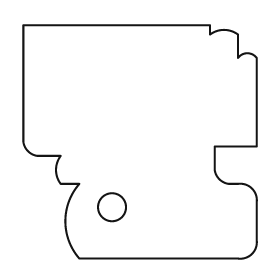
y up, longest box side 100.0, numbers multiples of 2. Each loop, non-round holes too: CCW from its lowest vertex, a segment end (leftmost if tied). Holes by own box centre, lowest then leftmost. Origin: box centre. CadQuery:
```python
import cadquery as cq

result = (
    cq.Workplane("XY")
    .moveTo(-26.0, -50.0)
    .lineTo(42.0, -50.0)
    .threePointArc((48.0, -48.0), (50.0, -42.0))
    .lineTo(50.0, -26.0)
    .threePointArc((48.0, -20.0), (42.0, -18.0))
    .lineTo(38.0, -18.0)
    .threePointArc((34.0, -16.0), (32.0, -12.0))
    .lineTo(32.0, -2.0)
    .lineTo(50.0, -2.0)
    .lineTo(50.0, 36.0)
    .threePointArc((46.0, 38.0), (42.0, 36.0))
    .lineTo(42.0, 46.0)
    .threePointArc((36.0, 48.0), (30.0, 46.0))
    .lineTo(30.0, 50.0)
    .lineTo(-50.0, 50.0)
    .lineTo(-50.0, 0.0)
    .threePointArc((-48.0, -4.0), (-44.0, -6.0))
    .lineTo(-34.0, -6.0)
    .threePointArc((-36.0, -12.0), (-34.0, -18.0))
    .lineTo(-26.0, -18.0)
    .threePointArc((-32.0, -34.0), (-26.0, -50.0))
    .close()
    .moveTo(-12.0, -28.0)
    .circle(6.0)
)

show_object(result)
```